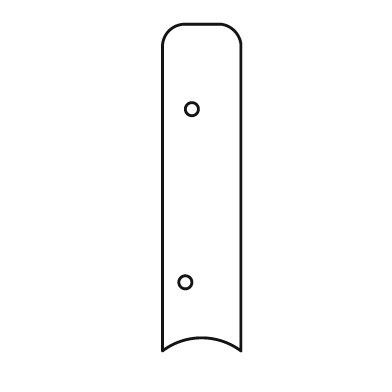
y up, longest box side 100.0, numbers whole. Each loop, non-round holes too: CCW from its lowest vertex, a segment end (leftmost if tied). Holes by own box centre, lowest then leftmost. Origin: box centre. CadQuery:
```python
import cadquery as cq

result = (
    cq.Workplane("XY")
    .moveTo(-12.0, -50.0)
    .threePointArc((0.0, -46.0), (12.0, -50.0))
    .lineTo(12.0, 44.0)
    .threePointArc((10.0, 48.0), (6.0, 50.0))
    .lineTo(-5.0, 50.0)
    .threePointArc((-10.0, 48.0), (-12.0, 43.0))
    .close()
    .moveTo(-5.0, -29.0)
    .circle(2.0)
    .moveTo(-3.0, 24.0)
    .circle(2.0)
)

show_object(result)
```